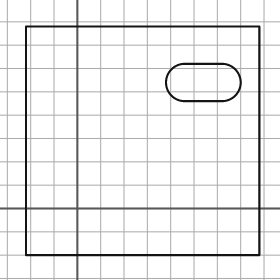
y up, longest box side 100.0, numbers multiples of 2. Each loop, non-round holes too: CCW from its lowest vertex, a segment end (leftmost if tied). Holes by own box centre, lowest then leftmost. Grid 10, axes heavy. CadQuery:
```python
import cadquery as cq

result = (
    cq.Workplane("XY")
    .moveTo(-22.0, -20.0)
    .lineTo(78.0, -20.0)
    .lineTo(78.0, 78.0)
    .lineTo(-22.0, 78.0)
    .close()
    .moveTo(46.0, 46.0)
    .lineTo(62.0, 46.0)
    .threePointArc((70.0, 54.0), (62.0, 62.0))
    .lineTo(46.0, 62.0)
    .threePointArc((38.0, 54.0), (46.0, 46.0))
    .close()
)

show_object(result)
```